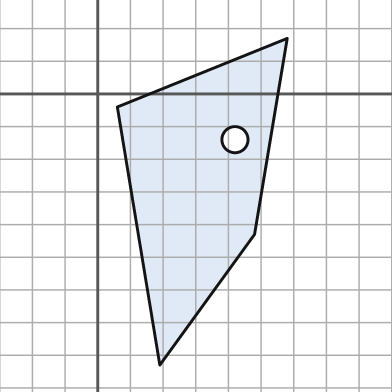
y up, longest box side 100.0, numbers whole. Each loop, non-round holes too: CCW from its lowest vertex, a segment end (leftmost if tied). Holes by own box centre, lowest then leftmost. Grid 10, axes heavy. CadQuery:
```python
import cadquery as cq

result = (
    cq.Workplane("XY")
    .moveTo(19.0, -83.0)
    .lineTo(48.0, -43.0)
    .lineTo(58.0, 17.0)
    .lineTo(6.0, -4.0)
    .close()
    .moveTo(42.0, -14.0)
    .circle(4.0)
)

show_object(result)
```